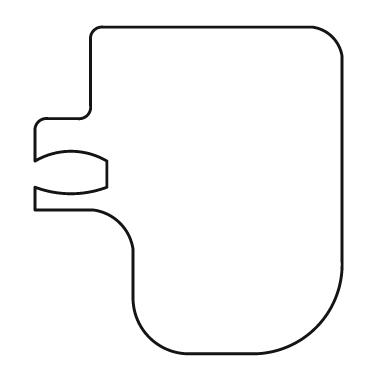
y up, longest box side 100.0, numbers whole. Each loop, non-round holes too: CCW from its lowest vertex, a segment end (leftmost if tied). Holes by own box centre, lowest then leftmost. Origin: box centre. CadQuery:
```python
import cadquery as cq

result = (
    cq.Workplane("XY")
    .moveTo(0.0, -50.0)
    .lineTo(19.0, -50.0)
    .threePointArc((39.0, -42.0), (47.0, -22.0))
    .lineTo(47.0, 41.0)
    .threePointArc((44.0, 47.0), (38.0, 50.0))
    .lineTo(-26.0, 50.0)
    .threePointArc((-29.0, 49.0), (-30.0, 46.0))
    .lineTo(-30.0, 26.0)
    .threePointArc((-31.0, 23.0), (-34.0, 22.0))
    .lineTo(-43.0, 22.0)
    .threePointArc((-46.0, 21.0), (-47.0, 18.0))
    .lineTo(-47.0, 9.0)
    .threePointArc((-36.0, 12.0), (-25.0, 9.0))
    .lineTo(-25.0, 1.0)
    .threePointArc((-36.0, -1.0), (-47.0, 1.0))
    .lineTo(-47.0, -6.0)
    .lineTo(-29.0, -6.0)
    .threePointArc((-21.0, -10.0), (-17.0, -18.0))
    .lineTo(-17.0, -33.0)
    .threePointArc((-12.0, -45.0), (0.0, -50.0))
    .close()
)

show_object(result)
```